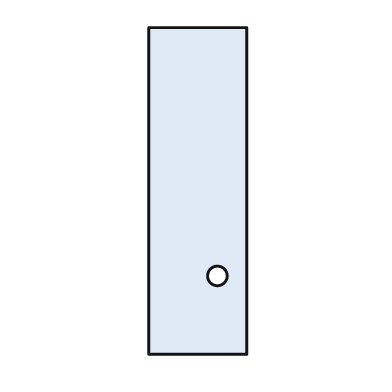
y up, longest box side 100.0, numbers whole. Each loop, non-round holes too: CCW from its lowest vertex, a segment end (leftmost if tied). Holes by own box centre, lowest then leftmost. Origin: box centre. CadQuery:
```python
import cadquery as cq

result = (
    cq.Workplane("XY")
    .moveTo(-15.0, -50.0)
    .lineTo(15.0, -50.0)
    .lineTo(15.0, 50.0)
    .lineTo(-15.0, 50.0)
    .close()
    .moveTo(6.0, -26.0)
    .circle(3.0)
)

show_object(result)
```